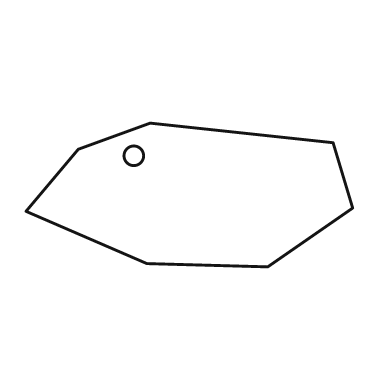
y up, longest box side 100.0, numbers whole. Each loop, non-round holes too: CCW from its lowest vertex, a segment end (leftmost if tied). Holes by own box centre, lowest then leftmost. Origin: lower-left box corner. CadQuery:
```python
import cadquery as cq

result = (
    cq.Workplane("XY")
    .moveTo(74.0, 0.0)
    .lineTo(100.0, 18.0)
    .lineTo(94.0, 38.0)
    .lineTo(38.0, 44.0)
    .lineTo(16.0, 36.0)
    .lineTo(0.0, 17.0)
    .lineTo(37.0, 1.0)
    .close()
    .moveTo(33.0, 34.0)
    .circle(3.0)
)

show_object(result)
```